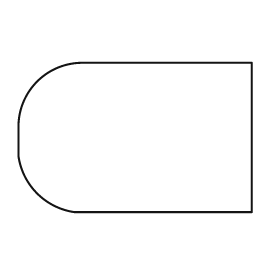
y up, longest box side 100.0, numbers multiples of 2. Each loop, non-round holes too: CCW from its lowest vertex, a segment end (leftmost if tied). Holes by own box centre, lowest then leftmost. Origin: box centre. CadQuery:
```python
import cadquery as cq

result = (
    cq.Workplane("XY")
    .moveTo(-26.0, -32.0)
    .lineTo(50.0, -32.0)
    .lineTo(50.0, 32.0)
    .lineTo(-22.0, 32.0)
    .threePointArc((-42.0, 24.0), (-50.0, 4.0))
    .lineTo(-50.0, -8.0)
    .threePointArc((-42.0, -24.0), (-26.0, -32.0))
    .close()
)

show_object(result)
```